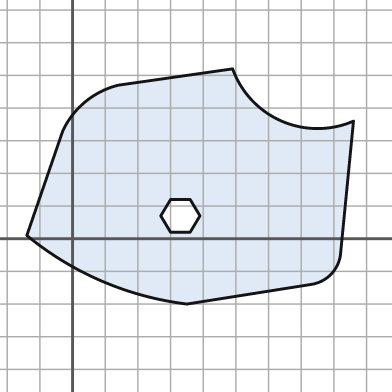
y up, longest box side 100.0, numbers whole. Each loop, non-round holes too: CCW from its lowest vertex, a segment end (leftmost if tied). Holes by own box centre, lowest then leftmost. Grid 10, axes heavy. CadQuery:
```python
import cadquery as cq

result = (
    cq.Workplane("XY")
    .moveTo(35.0, -20.0)
    .lineTo(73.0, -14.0)
    .threePointArc((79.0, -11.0), (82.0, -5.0))
    .lineTo(86.0, 36.0)
    .threePointArc((64.0, 36.0), (49.0, 52.0))
    .lineTo(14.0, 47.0)
    .threePointArc((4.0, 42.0), (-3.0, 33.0))
    .lineTo(-14.0, 1.0)
    .threePointArc((9.0, -13.0), (35.0, -20.0))
    .close()
    .moveTo(30.0, 2.0)
    .lineTo(36.0, 2.0)
    .lineTo(39.0, 7.0)
    .lineTo(36.0, 12.0)
    .lineTo(30.0, 12.0)
    .lineTo(27.0, 7.0)
    .close()
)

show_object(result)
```